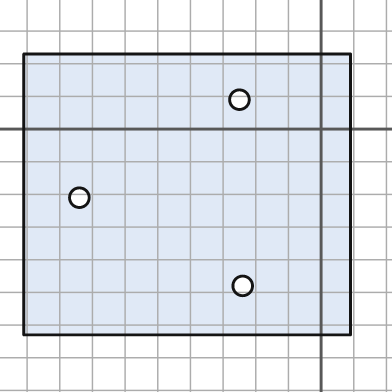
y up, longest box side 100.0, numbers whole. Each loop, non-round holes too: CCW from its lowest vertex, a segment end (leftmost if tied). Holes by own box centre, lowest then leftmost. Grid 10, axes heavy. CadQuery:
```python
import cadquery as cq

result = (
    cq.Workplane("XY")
    .moveTo(-91.0, -63.0)
    .lineTo(9.0, -63.0)
    .lineTo(9.0, 23.0)
    .lineTo(-91.0, 23.0)
    .close()
    .moveTo(-24.0, -48.0)
    .circle(3.0)
    .moveTo(-74.0, -21.0)
    .circle(3.0)
    .moveTo(-25.0, 9.0)
    .circle(3.0)
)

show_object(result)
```